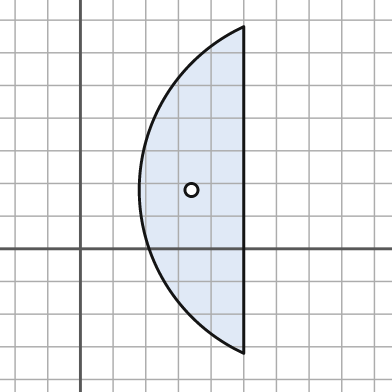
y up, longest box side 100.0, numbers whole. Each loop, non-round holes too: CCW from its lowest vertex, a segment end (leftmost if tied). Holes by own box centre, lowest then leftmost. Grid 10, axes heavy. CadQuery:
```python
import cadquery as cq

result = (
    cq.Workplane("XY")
    .moveTo(50.0, -32.0)
    .lineTo(50.0, 68.0)
    .threePointArc((18.0, 18.0), (50.0, -32.0))
    .close()
    .moveTo(34.0, 18.0)
    .circle(2.0)
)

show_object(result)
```